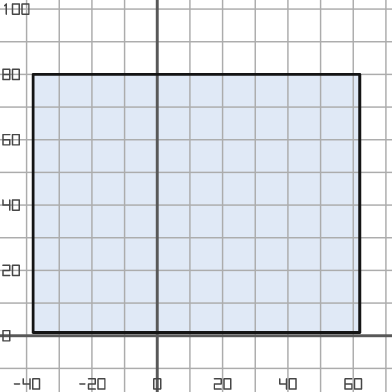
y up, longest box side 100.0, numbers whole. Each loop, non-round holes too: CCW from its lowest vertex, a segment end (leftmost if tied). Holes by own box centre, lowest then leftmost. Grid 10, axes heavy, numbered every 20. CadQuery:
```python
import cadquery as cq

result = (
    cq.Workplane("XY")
    .moveTo(-38.0, 1.0)
    .lineTo(62.0, 1.0)
    .lineTo(62.0, 80.0)
    .lineTo(-38.0, 80.0)
    .close()
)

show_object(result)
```